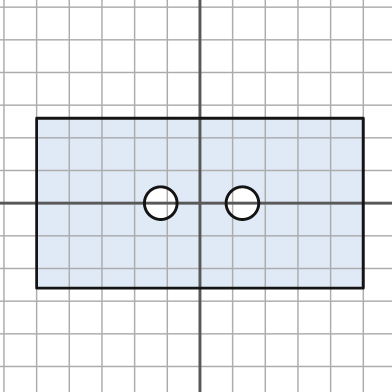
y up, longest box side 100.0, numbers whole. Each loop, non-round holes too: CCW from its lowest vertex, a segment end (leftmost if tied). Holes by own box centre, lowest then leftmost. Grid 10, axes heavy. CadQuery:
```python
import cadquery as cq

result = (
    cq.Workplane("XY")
    .moveTo(-50.0, -26.0)
    .lineTo(50.0, -26.0)
    .lineTo(50.0, 26.0)
    .lineTo(-50.0, 26.0)
    .close()
    .moveTo(-12.0, 0.0)
    .circle(5.0)
    .moveTo(13.0, 0.0)
    .circle(5.0)
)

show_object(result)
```